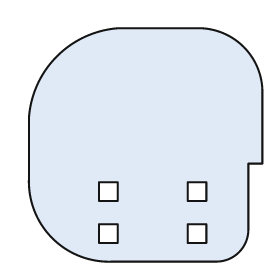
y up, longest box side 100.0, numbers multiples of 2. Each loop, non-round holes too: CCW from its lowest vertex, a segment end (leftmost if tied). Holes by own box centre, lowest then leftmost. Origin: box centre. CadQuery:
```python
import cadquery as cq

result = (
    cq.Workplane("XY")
    .moveTo(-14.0, -50.0)
    .lineTo(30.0, -50.0)
    .threePointArc((40.0, -46.0), (44.0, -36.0))
    .lineTo(44.0, -8.0)
    .lineTo(50.0, -8.0)
    .lineTo(50.0, 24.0)
    .threePointArc((42.0, 42.0), (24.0, 50.0))
    .lineTo(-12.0, 50.0)
    .threePointArc((-38.0, 38.0), (-50.0, 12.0))
    .lineTo(-50.0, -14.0)
    .threePointArc((-40.0, -40.0), (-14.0, -50.0))
    .close()
    .moveTo(-20.0, -42.0)
    .lineTo(-12.0, -42.0)
    .lineTo(-12.0, -34.0)
    .lineTo(-20.0, -34.0)
    .close()
    .moveTo(18.0, -42.0)
    .lineTo(26.0, -42.0)
    .lineTo(26.0, -34.0)
    .lineTo(18.0, -34.0)
    .close()
    .moveTo(-20.0, -24.0)
    .lineTo(-12.0, -24.0)
    .lineTo(-12.0, -16.0)
    .lineTo(-20.0, -16.0)
    .close()
    .moveTo(18.0, -24.0)
    .lineTo(26.0, -24.0)
    .lineTo(26.0, -16.0)
    .lineTo(18.0, -16.0)
    .close()
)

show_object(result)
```